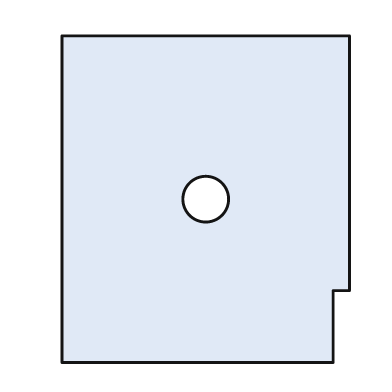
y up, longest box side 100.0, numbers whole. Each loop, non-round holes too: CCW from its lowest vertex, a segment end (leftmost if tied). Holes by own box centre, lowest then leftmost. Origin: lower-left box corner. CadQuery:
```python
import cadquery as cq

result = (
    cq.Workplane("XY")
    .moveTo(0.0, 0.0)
    .lineTo(83.0, 0.0)
    .lineTo(83.0, 22.0)
    .lineTo(88.0, 22.0)
    .lineTo(88.0, 100.0)
    .lineTo(0.0, 100.0)
    .close()
    .moveTo(44.0, 50.0)
    .circle(7.0)
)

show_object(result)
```